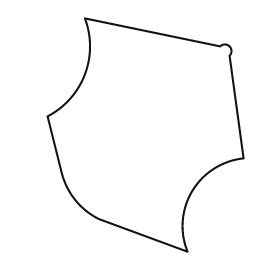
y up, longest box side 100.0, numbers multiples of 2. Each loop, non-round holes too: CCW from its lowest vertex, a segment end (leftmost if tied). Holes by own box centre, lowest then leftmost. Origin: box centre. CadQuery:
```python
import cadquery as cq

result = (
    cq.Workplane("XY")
    .moveTo(18.0, -50.0)
    .threePointArc((20.0, -24.0), (42.0, -10.0))
    .lineTo(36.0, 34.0)
    .threePointArc((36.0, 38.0), (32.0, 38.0))
    .lineTo(-26.0, 50.0)
    .threePointArc((-26.0, 26.0), (-42.0, 8.0))
    .lineTo(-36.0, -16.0)
    .threePointArc((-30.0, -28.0), (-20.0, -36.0))
    .close()
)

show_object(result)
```